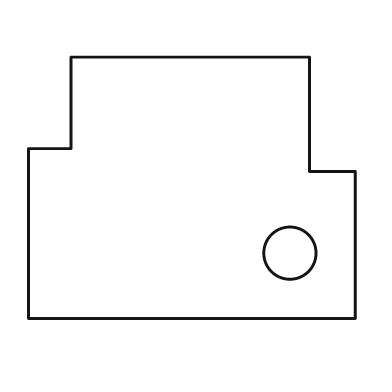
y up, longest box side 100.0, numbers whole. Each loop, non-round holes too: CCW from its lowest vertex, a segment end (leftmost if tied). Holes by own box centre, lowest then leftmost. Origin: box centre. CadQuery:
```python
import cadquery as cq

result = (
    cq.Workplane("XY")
    .moveTo(-50.0, -40.0)
    .lineTo(50.0, -40.0)
    .lineTo(50.0, 5.0)
    .lineTo(36.0, 5.0)
    .lineTo(36.0, 40.0)
    .lineTo(-37.0, 40.0)
    .lineTo(-37.0, 12.0)
    .lineTo(-50.0, 12.0)
    .close()
    .moveTo(30.0, -20.0)
    .circle(8.0)
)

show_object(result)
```